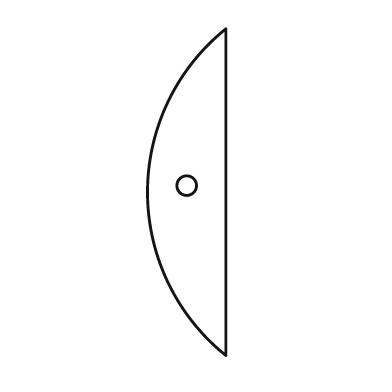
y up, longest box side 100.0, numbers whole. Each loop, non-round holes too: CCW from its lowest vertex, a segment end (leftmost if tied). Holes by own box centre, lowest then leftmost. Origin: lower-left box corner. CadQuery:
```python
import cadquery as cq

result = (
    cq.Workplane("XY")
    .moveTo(24.0, 0.0)
    .lineTo(24.0, 100.0)
    .threePointArc((0.0, 50.0), (24.0, 0.0))
    .close()
    .moveTo(12.0, 52.0)
    .circle(3.0)
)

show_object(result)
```